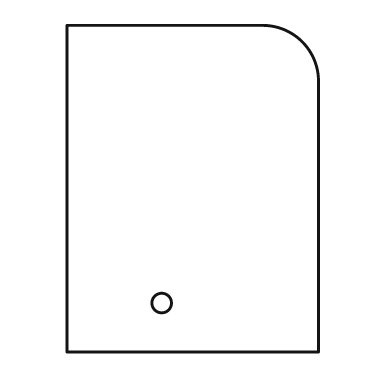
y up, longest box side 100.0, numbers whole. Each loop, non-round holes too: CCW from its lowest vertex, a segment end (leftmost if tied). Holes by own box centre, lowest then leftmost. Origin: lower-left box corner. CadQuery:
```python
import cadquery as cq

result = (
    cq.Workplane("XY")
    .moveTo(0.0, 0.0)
    .lineTo(77.0, 0.0)
    .lineTo(77.0, 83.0)
    .threePointArc((72.0, 95.0), (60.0, 100.0))
    .lineTo(0.0, 100.0)
    .close()
    .moveTo(29.0, 15.0)
    .circle(3.0)
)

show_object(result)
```